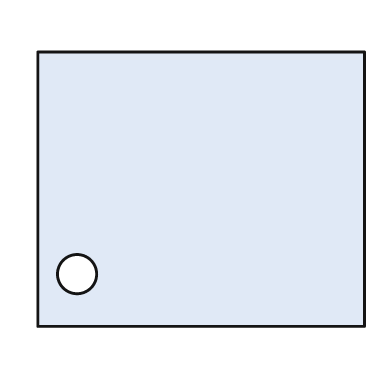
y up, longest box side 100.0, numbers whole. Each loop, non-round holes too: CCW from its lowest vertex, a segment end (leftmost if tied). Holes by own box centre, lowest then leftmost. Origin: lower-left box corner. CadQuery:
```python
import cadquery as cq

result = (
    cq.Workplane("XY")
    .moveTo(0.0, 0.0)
    .lineTo(100.0, 0.0)
    .lineTo(100.0, 84.0)
    .lineTo(0.0, 84.0)
    .close()
    .moveTo(12.0, 16.0)
    .circle(6.0)
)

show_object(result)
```